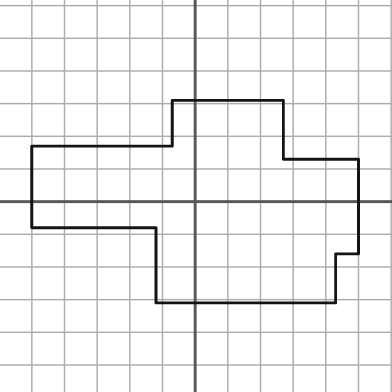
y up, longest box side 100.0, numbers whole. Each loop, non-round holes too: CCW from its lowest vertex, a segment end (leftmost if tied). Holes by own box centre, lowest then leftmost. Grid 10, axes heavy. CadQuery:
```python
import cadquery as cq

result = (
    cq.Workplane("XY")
    .moveTo(-12.0, -31.0)
    .lineTo(43.0, -31.0)
    .lineTo(43.0, -16.0)
    .lineTo(50.0, -16.0)
    .lineTo(50.0, 13.0)
    .lineTo(27.0, 13.0)
    .lineTo(27.0, 31.0)
    .lineTo(-7.0, 31.0)
    .lineTo(-7.0, 17.0)
    .lineTo(-50.0, 17.0)
    .lineTo(-50.0, -8.0)
    .lineTo(-12.0, -8.0)
    .close()
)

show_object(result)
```